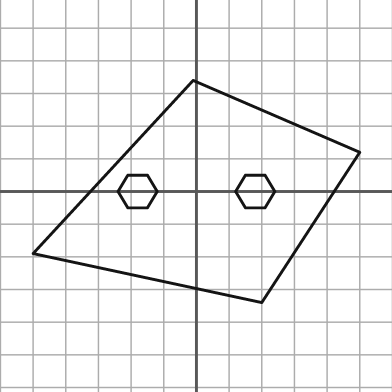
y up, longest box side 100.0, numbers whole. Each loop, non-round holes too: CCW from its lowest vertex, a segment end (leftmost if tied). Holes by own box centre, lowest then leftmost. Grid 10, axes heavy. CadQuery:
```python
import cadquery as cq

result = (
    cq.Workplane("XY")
    .moveTo(20.0, -34.0)
    .lineTo(50.0, 12.0)
    .lineTo(-1.0, 34.0)
    .lineTo(-50.0, -19.0)
    .close()
    .moveTo(-21.0, -5.0)
    .lineTo(-15.0, -5.0)
    .lineTo(-12.0, 0.0)
    .lineTo(-15.0, 5.0)
    .lineTo(-21.0, 5.0)
    .lineTo(-24.0, 0.0)
    .close()
    .moveTo(15.0, -5.0)
    .lineTo(21.0, -5.0)
    .lineTo(24.0, 0.0)
    .lineTo(21.0, 5.0)
    .lineTo(15.0, 5.0)
    .lineTo(12.0, 0.0)
    .close()
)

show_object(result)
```